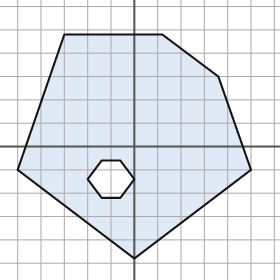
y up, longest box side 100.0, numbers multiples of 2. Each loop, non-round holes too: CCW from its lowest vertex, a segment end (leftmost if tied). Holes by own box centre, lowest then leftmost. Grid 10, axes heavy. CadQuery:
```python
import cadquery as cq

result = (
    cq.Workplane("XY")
    .moveTo(0.0, -48.0)
    .lineTo(50.0, -10.0)
    .lineTo(36.0, 30.0)
    .lineTo(12.0, 48.0)
    .lineTo(-30.0, 48.0)
    .lineTo(-50.0, -10.0)
    .close()
    .moveTo(-14.0, -22.0)
    .lineTo(-6.0, -22.0)
    .lineTo(0.0, -14.0)
    .lineTo(-6.0, -6.0)
    .lineTo(-14.0, -6.0)
    .lineTo(-20.0, -14.0)
    .close()
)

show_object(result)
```